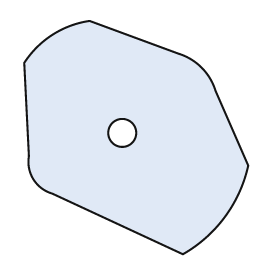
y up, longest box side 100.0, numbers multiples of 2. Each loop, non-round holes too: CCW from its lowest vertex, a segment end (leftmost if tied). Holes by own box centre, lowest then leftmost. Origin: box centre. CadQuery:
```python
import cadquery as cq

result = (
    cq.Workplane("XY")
    .moveTo(20.0, -50.0)
    .threePointArc((38.0, -34.0), (48.0, -12.0))
    .lineTo(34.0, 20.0)
    .threePointArc((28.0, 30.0), (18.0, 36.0))
    .lineTo(-20.0, 50.0)
    .threePointArc((-36.0, 44.0), (-48.0, 32.0))
    .lineTo(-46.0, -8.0)
    .threePointArc((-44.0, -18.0), (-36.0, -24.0))
    .close()
    .moveTo(-6.0, 2.0)
    .circle(6.0)
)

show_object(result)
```